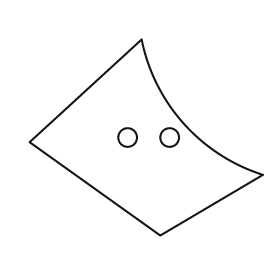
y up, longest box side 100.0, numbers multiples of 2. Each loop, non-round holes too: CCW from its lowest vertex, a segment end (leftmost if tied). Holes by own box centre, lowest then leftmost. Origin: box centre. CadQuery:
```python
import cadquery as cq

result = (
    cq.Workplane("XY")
    .moveTo(6.0, -42.0)
    .lineTo(50.0, -16.0)
    .threePointArc((16.0, 6.0), (-2.0, 42.0))
    .lineTo(-50.0, -2.0)
    .close()
    .moveTo(-8.0, 0.0)
    .circle(4.0)
    .moveTo(10.0, 0.0)
    .circle(4.0)
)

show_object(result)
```